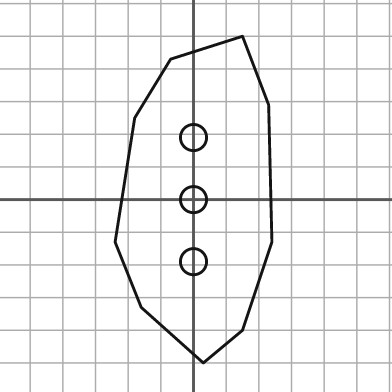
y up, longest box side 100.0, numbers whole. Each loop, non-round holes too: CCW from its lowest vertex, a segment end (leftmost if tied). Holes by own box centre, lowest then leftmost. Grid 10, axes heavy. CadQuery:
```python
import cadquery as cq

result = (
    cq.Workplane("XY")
    .moveTo(3.0, -50.0)
    .lineTo(15.0, -40.0)
    .lineTo(24.0, -13.0)
    .lineTo(23.0, 29.0)
    .lineTo(15.0, 50.0)
    .lineTo(-7.0, 43.0)
    .lineTo(-18.0, 25.0)
    .lineTo(-24.0, -13.0)
    .lineTo(-16.0, -33.0)
    .close()
    .moveTo(0.0, -19.0)
    .circle(4.0)
    .moveTo(0.0, 0.0)
    .circle(4.0)
    .moveTo(0.0, 19.0)
    .circle(4.0)
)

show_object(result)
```